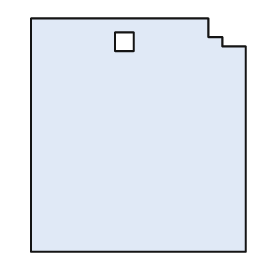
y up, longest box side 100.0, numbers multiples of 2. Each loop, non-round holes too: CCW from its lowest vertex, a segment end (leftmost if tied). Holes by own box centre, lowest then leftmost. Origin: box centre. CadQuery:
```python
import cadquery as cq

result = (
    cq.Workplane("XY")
    .moveTo(-46.0, -50.0)
    .lineTo(46.0, -50.0)
    .lineTo(46.0, 38.0)
    .lineTo(36.0, 38.0)
    .lineTo(36.0, 42.0)
    .lineTo(30.0, 42.0)
    .lineTo(30.0, 50.0)
    .lineTo(-46.0, 50.0)
    .close()
    .moveTo(-10.0, 36.0)
    .lineTo(-2.0, 36.0)
    .lineTo(-2.0, 44.0)
    .lineTo(-10.0, 44.0)
    .close()
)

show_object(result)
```